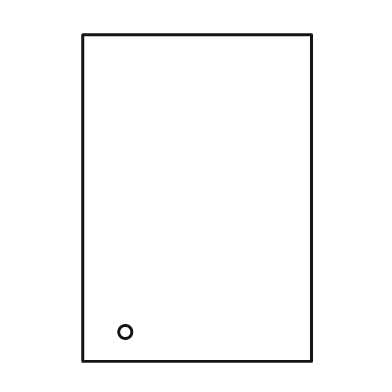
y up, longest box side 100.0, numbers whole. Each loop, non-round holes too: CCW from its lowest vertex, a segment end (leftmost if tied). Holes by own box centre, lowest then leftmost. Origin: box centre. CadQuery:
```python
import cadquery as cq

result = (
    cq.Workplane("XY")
    .moveTo(-35.0, -50.0)
    .lineTo(35.0, -50.0)
    .lineTo(35.0, 50.0)
    .lineTo(-35.0, 50.0)
    .close()
    .moveTo(-22.0, -41.0)
    .circle(2.0)
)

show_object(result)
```